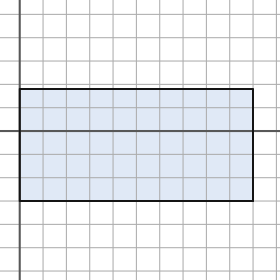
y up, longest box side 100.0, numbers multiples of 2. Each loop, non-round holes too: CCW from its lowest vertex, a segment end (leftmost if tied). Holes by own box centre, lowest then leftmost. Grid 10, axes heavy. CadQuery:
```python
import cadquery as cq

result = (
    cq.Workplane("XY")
    .moveTo(0.0, -30.0)
    .lineTo(100.0, -30.0)
    .lineTo(100.0, 18.0)
    .lineTo(0.0, 18.0)
    .close()
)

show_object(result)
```